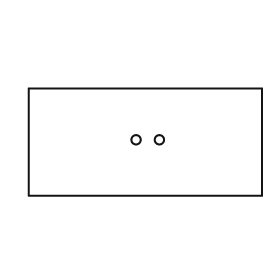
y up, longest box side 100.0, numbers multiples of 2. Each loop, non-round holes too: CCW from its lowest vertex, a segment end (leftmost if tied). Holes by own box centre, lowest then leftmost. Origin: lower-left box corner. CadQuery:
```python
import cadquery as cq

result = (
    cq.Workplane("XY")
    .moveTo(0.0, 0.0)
    .lineTo(100.0, 0.0)
    .lineTo(100.0, 46.0)
    .lineTo(0.0, 46.0)
    .close()
    .moveTo(46.0, 24.0)
    .circle(2.0)
    .moveTo(56.0, 24.0)
    .circle(2.0)
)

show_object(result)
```